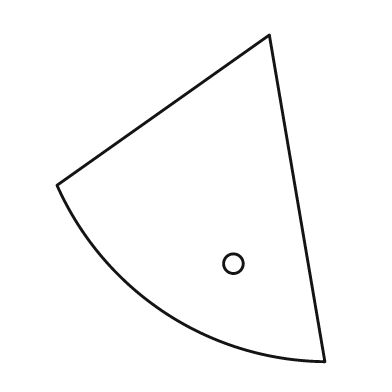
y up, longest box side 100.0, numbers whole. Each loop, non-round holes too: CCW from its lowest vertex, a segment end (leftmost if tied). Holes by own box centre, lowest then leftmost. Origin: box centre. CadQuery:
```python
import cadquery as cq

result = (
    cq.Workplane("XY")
    .moveTo(41.0, -50.0)
    .lineTo(24.0, 50.0)
    .lineTo(-41.0, 4.0)
    .threePointArc((-8.0, -35.0), (41.0, -50.0))
    .close()
    .moveTo(13.0, -20.0)
    .circle(3.0)
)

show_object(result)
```